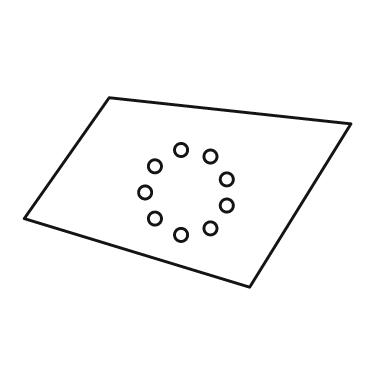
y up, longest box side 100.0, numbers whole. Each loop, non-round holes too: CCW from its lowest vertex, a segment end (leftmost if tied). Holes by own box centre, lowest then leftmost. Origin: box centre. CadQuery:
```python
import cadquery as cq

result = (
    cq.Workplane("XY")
    .moveTo(19.0, -29.0)
    .lineTo(50.0, 21.0)
    .lineTo(-24.0, 29.0)
    .lineTo(-50.0, -8.0)
    .close()
    .moveTo(-2.0, -13.0)
    .circle(2.0)
    .moveTo(7.0, -11.0)
    .circle(2.0)
    .moveTo(-10.0, -8.0)
    .circle(2.0)
    .moveTo(12.0, -4.0)
    .circle(2.0)
    .moveTo(-13.0, 0.0)
    .circle(2.0)
    .moveTo(12.0, 4.0)
    .circle(2.0)
    .moveTo(-10.0, 8.0)
    .circle(2.0)
    .moveTo(7.0, 11.0)
    .circle(2.0)
    .moveTo(-2.0, 13.0)
    .circle(2.0)
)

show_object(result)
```